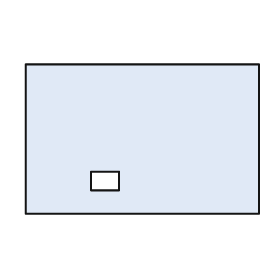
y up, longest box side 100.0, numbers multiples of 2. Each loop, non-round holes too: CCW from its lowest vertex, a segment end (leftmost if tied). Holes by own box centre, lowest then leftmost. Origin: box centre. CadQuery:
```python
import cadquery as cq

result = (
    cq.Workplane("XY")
    .moveTo(-50.0, -32.0)
    .lineTo(50.0, -32.0)
    .lineTo(50.0, 32.0)
    .lineTo(-50.0, 32.0)
    .close()
    .moveTo(-22.0, -22.0)
    .lineTo(-10.0, -22.0)
    .lineTo(-10.0, -14.0)
    .lineTo(-22.0, -14.0)
    .close()
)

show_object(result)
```